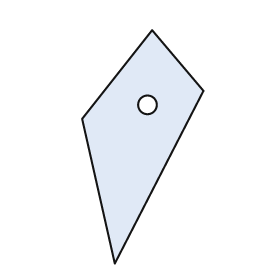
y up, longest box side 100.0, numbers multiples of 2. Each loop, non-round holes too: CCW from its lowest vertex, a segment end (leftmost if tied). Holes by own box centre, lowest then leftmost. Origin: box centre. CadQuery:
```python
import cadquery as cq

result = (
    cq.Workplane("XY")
    .moveTo(-12.0, -50.0)
    .lineTo(26.0, 24.0)
    .lineTo(4.0, 50.0)
    .lineTo(-26.0, 12.0)
    .close()
    .moveTo(2.0, 18.0)
    .circle(4.0)
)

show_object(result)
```